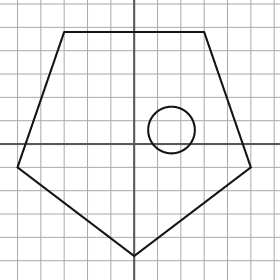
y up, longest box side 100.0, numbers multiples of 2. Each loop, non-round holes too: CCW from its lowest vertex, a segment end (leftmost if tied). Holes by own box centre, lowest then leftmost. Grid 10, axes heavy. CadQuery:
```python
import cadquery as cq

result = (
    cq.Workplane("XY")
    .moveTo(0.0, -48.0)
    .lineTo(50.0, -10.0)
    .lineTo(30.0, 48.0)
    .lineTo(-30.0, 48.0)
    .lineTo(-50.0, -10.0)
    .close()
    .moveTo(16.0, 6.0)
    .circle(10.0)
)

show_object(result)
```